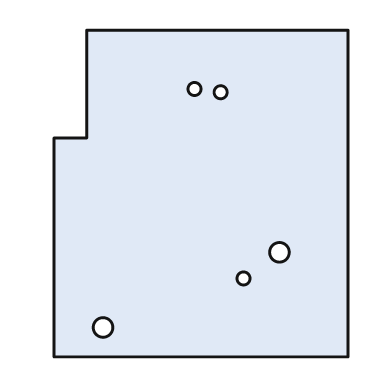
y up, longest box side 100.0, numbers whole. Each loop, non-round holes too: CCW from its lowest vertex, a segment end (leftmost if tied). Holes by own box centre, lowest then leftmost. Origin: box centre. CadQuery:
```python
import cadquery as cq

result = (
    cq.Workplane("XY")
    .moveTo(-45.0, -50.0)
    .lineTo(45.0, -50.0)
    .lineTo(45.0, 50.0)
    .lineTo(-35.0, 50.0)
    .lineTo(-35.0, 17.0)
    .lineTo(-45.0, 17.0)
    .close()
    .moveTo(-30.0, -41.0)
    .circle(3.0)
    .moveTo(13.0, -26.0)
    .circle(2.0)
    .moveTo(24.0, -18.0)
    .circle(3.0)
    .moveTo(6.0, 31.0)
    .circle(2.0)
    .moveTo(-2.0, 32.0)
    .circle(2.0)
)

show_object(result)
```